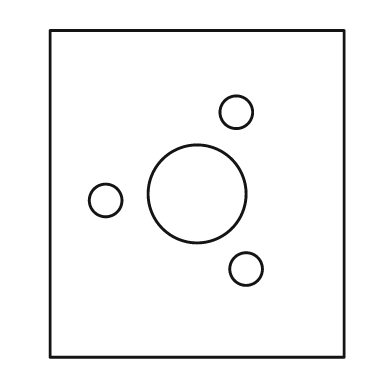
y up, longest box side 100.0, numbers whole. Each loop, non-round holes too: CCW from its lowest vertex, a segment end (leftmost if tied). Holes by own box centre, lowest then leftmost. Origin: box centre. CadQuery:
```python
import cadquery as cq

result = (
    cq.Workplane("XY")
    .moveTo(-45.0, -50.0)
    .lineTo(45.0, -50.0)
    .lineTo(45.0, 50.0)
    .lineTo(-45.0, 50.0)
    .close()
    .moveTo(15.0, -23.0)
    .circle(5.0)
    .moveTo(-28.0, -2.0)
    .circle(5.0)
    .moveTo(0.0, 0.0)
    .circle(15.0)
    .moveTo(12.0, 25.0)
    .circle(5.0)
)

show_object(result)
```